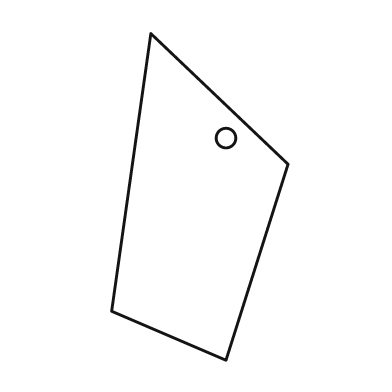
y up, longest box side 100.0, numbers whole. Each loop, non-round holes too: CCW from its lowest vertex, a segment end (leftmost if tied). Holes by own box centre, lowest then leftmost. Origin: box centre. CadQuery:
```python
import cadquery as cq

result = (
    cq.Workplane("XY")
    .moveTo(8.0, -50.0)
    .lineTo(27.0, 10.0)
    .lineTo(-15.0, 50.0)
    .lineTo(-27.0, -35.0)
    .close()
    .moveTo(8.0, 18.0)
    .circle(3.0)
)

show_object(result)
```